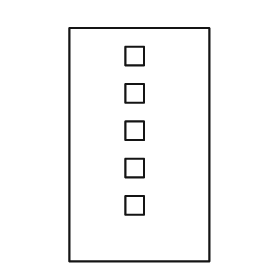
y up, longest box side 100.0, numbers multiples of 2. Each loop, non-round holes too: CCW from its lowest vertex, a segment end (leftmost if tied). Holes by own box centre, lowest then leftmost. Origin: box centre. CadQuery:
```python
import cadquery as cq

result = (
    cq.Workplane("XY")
    .moveTo(-30.0, -50.0)
    .lineTo(30.0, -50.0)
    .lineTo(30.0, 50.0)
    .lineTo(-30.0, 50.0)
    .close()
    .moveTo(-6.0, -30.0)
    .lineTo(2.0, -30.0)
    .lineTo(2.0, -22.0)
    .lineTo(-6.0, -22.0)
    .close()
    .moveTo(-6.0, -14.0)
    .lineTo(2.0, -14.0)
    .lineTo(2.0, -6.0)
    .lineTo(-6.0, -6.0)
    .close()
    .moveTo(-6.0, 2.0)
    .lineTo(2.0, 2.0)
    .lineTo(2.0, 10.0)
    .lineTo(-6.0, 10.0)
    .close()
    .moveTo(-6.0, 18.0)
    .lineTo(2.0, 18.0)
    .lineTo(2.0, 26.0)
    .lineTo(-6.0, 26.0)
    .close()
    .moveTo(-6.0, 34.0)
    .lineTo(2.0, 34.0)
    .lineTo(2.0, 42.0)
    .lineTo(-6.0, 42.0)
    .close()
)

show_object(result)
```